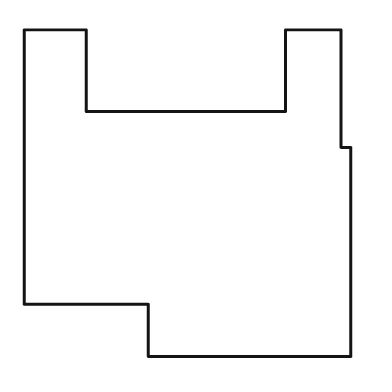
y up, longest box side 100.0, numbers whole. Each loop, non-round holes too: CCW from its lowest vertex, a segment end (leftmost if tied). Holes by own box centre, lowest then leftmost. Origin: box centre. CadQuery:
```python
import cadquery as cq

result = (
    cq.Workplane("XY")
    .moveTo(-12.0, -50.0)
    .lineTo(50.0, -50.0)
    .lineTo(50.0, 14.0)
    .lineTo(47.0, 14.0)
    .lineTo(47.0, 50.0)
    .lineTo(30.0, 50.0)
    .lineTo(30.0, 25.0)
    .lineTo(-31.0, 25.0)
    .lineTo(-31.0, 50.0)
    .lineTo(-50.0, 50.0)
    .lineTo(-50.0, -34.0)
    .lineTo(-12.0, -34.0)
    .close()
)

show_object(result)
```